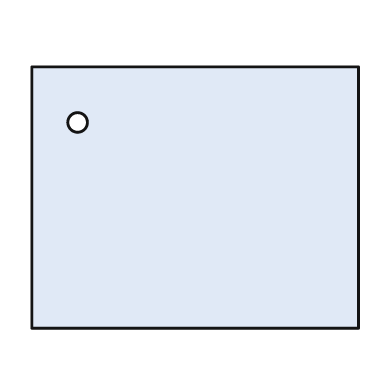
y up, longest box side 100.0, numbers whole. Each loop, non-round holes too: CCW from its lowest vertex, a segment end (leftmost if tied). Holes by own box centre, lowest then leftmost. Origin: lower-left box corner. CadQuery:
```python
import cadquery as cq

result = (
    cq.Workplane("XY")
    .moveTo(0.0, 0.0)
    .lineTo(100.0, 0.0)
    .lineTo(100.0, 80.0)
    .lineTo(0.0, 80.0)
    .close()
    .moveTo(14.0, 63.0)
    .circle(3.0)
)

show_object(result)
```